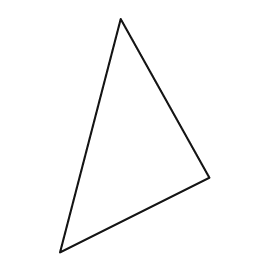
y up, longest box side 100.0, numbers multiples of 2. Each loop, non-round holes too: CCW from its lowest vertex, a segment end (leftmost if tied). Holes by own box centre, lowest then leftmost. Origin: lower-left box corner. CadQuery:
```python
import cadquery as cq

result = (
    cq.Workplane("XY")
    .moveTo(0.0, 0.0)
    .lineTo(64.0, 32.0)
    .lineTo(26.0, 100.0)
    .close()
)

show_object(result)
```